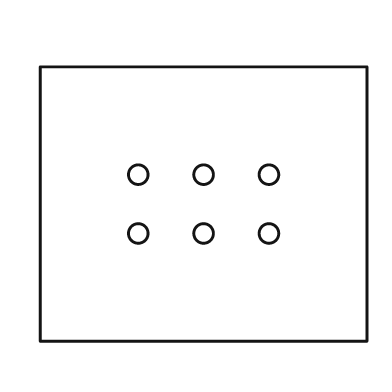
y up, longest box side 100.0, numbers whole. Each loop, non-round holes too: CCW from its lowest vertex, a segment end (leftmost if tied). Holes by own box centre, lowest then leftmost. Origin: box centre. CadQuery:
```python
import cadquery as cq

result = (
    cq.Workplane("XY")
    .moveTo(-50.0, -42.0)
    .lineTo(50.0, -42.0)
    .lineTo(50.0, 42.0)
    .lineTo(-50.0, 42.0)
    .close()
    .moveTo(-20.0, -9.0)
    .circle(3.0)
    .moveTo(0.0, -9.0)
    .circle(3.0)
    .moveTo(20.0, -9.0)
    .circle(3.0)
    .moveTo(-20.0, 9.0)
    .circle(3.0)
    .moveTo(0.0, 9.0)
    .circle(3.0)
    .moveTo(20.0, 9.0)
    .circle(3.0)
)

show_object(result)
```